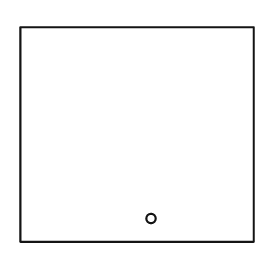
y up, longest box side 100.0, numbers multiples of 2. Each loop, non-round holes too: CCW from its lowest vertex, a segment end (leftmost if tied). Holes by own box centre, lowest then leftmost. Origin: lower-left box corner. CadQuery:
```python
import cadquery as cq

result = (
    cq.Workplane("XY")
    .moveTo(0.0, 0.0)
    .lineTo(100.0, 0.0)
    .lineTo(100.0, 92.0)
    .lineTo(0.0, 92.0)
    .close()
    .moveTo(56.0, 10.0)
    .circle(2.0)
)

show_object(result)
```